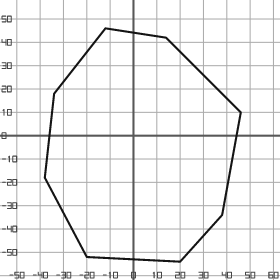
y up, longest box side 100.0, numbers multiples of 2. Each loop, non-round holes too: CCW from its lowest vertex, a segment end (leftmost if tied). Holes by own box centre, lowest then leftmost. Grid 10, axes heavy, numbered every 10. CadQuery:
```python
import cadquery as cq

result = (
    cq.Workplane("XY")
    .moveTo(20.0, -54.0)
    .lineTo(38.0, -34.0)
    .lineTo(46.0, 10.0)
    .lineTo(14.0, 42.0)
    .lineTo(-12.0, 46.0)
    .lineTo(-34.0, 18.0)
    .lineTo(-38.0, -18.0)
    .lineTo(-20.0, -52.0)
    .close()
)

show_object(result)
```